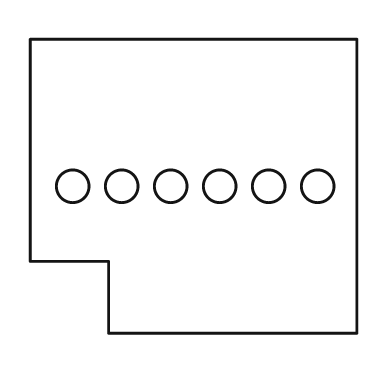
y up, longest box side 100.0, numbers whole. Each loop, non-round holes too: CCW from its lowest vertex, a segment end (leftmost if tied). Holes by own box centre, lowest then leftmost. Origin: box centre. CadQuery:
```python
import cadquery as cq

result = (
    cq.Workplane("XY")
    .moveTo(-26.0, -45.0)
    .lineTo(50.0, -45.0)
    .lineTo(50.0, 45.0)
    .lineTo(-50.0, 45.0)
    .lineTo(-50.0, -23.0)
    .lineTo(-26.0, -23.0)
    .close()
    .moveTo(-37.0, 0.0)
    .circle(5.0)
    .moveTo(-22.0, 0.0)
    .circle(5.0)
    .moveTo(-7.0, 0.0)
    .circle(5.0)
    .moveTo(8.0, 0.0)
    .circle(5.0)
    .moveTo(23.0, 0.0)
    .circle(5.0)
    .moveTo(38.0, 0.0)
    .circle(5.0)
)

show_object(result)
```